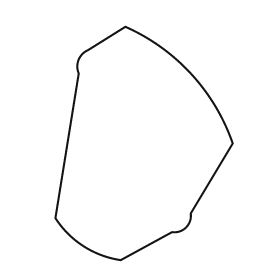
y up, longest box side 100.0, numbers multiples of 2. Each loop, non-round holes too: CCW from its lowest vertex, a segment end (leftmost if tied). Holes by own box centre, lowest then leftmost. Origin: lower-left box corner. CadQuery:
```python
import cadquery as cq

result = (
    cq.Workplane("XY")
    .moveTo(28.0, 0.0)
    .lineTo(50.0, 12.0)
    .threePointArc((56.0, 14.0), (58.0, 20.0))
    .lineTo(76.0, 50.0)
    .threePointArc((58.0, 80.0), (30.0, 100.0))
    .lineTo(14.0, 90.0)
    .threePointArc((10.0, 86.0), (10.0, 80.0))
    .lineTo(0.0, 18.0)
    .threePointArc((12.0, 6.0), (28.0, 0.0))
    .close()
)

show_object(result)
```